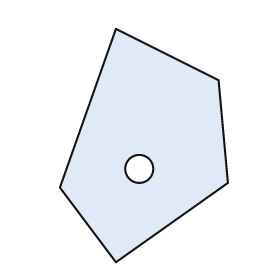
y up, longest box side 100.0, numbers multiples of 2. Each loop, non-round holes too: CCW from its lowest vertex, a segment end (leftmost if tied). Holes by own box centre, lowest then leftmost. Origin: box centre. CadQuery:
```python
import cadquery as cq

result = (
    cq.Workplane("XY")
    .moveTo(-12.0, -50.0)
    .lineTo(36.0, -16.0)
    .lineTo(32.0, 28.0)
    .lineTo(-12.0, 50.0)
    .lineTo(-36.0, -18.0)
    .close()
    .moveTo(-2.0, -10.0)
    .circle(6.0)
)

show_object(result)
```